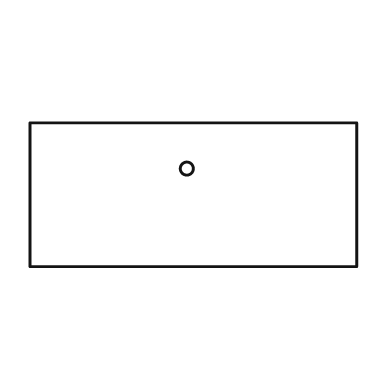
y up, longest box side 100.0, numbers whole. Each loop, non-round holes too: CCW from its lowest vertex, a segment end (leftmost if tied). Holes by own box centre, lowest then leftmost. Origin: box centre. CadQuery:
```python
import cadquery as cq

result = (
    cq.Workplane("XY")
    .moveTo(-50.0, -22.0)
    .lineTo(50.0, -22.0)
    .lineTo(50.0, 22.0)
    .lineTo(-50.0, 22.0)
    .close()
    .moveTo(-2.0, 8.0)
    .circle(2.0)
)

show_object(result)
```